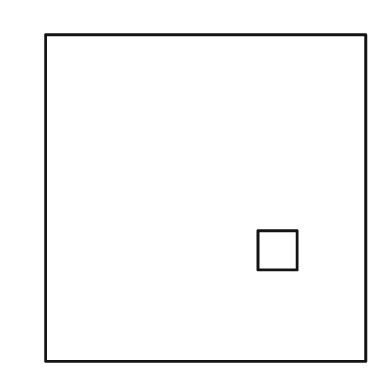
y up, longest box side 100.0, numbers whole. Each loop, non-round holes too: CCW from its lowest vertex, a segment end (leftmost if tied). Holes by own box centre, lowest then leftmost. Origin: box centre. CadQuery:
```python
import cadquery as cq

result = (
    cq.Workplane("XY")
    .moveTo(-49.0, -50.0)
    .lineTo(49.0, -50.0)
    .lineTo(49.0, 50.0)
    .lineTo(-49.0, 50.0)
    .close()
    .moveTo(16.0, -22.0)
    .lineTo(28.0, -22.0)
    .lineTo(28.0, -10.0)
    .lineTo(16.0, -10.0)
    .close()
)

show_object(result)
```